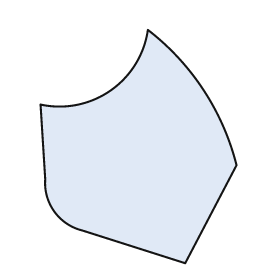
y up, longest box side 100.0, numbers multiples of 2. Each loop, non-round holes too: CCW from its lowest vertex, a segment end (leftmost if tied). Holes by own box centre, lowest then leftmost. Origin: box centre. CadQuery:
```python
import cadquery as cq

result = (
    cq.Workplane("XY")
    .moveTo(20.0, -50.0)
    .lineTo(42.0, -8.0)
    .threePointArc((28.0, 24.0), (4.0, 50.0))
    .threePointArc((-12.0, 24.0), (-42.0, 18.0))
    .lineTo(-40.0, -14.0)
    .threePointArc((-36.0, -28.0), (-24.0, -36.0))
    .close()
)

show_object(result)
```